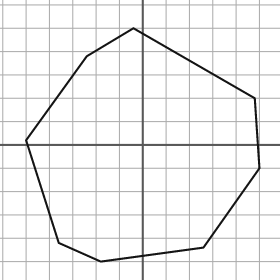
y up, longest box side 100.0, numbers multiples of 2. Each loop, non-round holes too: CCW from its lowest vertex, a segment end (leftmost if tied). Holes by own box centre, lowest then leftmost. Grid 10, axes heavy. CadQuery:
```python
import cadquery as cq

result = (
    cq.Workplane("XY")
    .moveTo(-18.0, -50.0)
    .lineTo(26.0, -44.0)
    .lineTo(50.0, -10.0)
    .lineTo(48.0, 20.0)
    .lineTo(-4.0, 50.0)
    .lineTo(-24.0, 38.0)
    .lineTo(-50.0, 2.0)
    .lineTo(-36.0, -42.0)
    .close()
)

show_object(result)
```